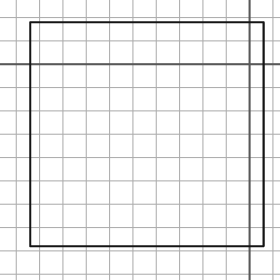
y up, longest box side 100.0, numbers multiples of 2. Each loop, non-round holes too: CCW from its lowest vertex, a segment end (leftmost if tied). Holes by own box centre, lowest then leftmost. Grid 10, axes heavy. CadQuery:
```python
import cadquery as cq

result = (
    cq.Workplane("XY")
    .moveTo(-94.0, -78.0)
    .lineTo(6.0, -78.0)
    .lineTo(6.0, 18.0)
    .lineTo(-94.0, 18.0)
    .close()
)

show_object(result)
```